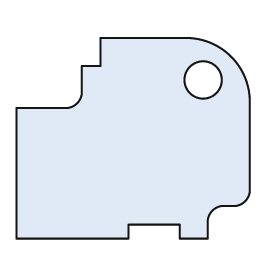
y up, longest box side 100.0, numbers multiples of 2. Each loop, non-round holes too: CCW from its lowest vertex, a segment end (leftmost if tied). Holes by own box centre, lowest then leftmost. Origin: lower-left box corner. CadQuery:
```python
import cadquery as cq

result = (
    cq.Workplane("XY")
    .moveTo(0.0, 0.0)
    .lineTo(48.0, 0.0)
    .lineTo(48.0, 6.0)
    .lineTo(70.0, 6.0)
    .lineTo(70.0, 0.0)
    .lineTo(82.0, 0.0)
    .lineTo(82.0, 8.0)
    .threePointArc((84.0, 12.0), (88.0, 14.0))
    .lineTo(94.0, 14.0)
    .threePointArc((98.0, 16.0), (100.0, 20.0))
    .lineTo(100.0, 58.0)
    .threePointArc((92.0, 78.0), (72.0, 86.0))
    .lineTo(36.0, 86.0)
    .lineTo(36.0, 74.0)
    .lineTo(28.0, 74.0)
    .lineTo(28.0, 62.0)
    .threePointArc((26.0, 58.0), (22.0, 56.0))
    .lineTo(0.0, 56.0)
    .close()
    .moveTo(80.0, 68.0)
    .circle(8.0)
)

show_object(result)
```